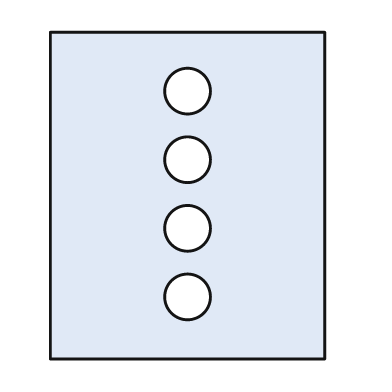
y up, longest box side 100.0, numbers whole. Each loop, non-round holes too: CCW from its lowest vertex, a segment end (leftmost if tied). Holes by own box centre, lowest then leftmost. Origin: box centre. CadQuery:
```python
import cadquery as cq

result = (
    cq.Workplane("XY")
    .moveTo(-42.0, -50.0)
    .lineTo(42.0, -50.0)
    .lineTo(42.0, 50.0)
    .lineTo(-42.0, 50.0)
    .close()
    .moveTo(0.0, -31.0)
    .circle(7.0)
    .moveTo(0.0, -10.0)
    .circle(7.0)
    .moveTo(0.0, 11.0)
    .circle(7.0)
    .moveTo(0.0, 32.0)
    .circle(7.0)
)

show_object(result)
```